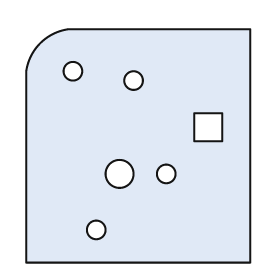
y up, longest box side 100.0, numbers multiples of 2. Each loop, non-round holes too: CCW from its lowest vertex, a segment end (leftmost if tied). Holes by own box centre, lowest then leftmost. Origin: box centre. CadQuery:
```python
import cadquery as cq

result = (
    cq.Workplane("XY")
    .moveTo(-48.0, -50.0)
    .lineTo(48.0, -50.0)
    .lineTo(48.0, 50.0)
    .lineTo(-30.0, 50.0)
    .threePointArc((-42.0, 44.0), (-48.0, 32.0))
    .close()
    .moveTo(-18.0, -36.0)
    .circle(4.0)
    .moveTo(-8.0, -12.0)
    .circle(6.0)
    .moveTo(12.0, -12.0)
    .circle(4.0)
    .moveTo(24.0, 2.0)
    .lineTo(36.0, 2.0)
    .lineTo(36.0, 14.0)
    .lineTo(24.0, 14.0)
    .close()
    .moveTo(-2.0, 28.0)
    .circle(4.0)
    .moveTo(-28.0, 32.0)
    .circle(4.0)
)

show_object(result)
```